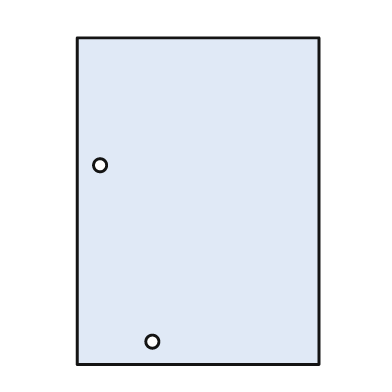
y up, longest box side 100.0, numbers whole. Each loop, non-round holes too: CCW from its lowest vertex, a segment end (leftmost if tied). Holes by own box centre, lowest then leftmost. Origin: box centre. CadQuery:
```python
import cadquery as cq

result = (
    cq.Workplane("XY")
    .moveTo(-37.0, -50.0)
    .lineTo(37.0, -50.0)
    .lineTo(37.0, 50.0)
    .lineTo(-37.0, 50.0)
    .close()
    .moveTo(-14.0, -43.0)
    .circle(2.0)
    .moveTo(-30.0, 11.0)
    .circle(2.0)
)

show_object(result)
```